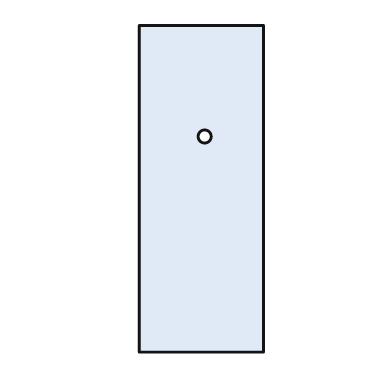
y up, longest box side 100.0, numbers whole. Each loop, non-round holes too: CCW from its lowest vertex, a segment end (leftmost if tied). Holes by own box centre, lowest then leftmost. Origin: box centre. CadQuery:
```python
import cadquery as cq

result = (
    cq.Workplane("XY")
    .moveTo(-19.0, -50.0)
    .lineTo(19.0, -50.0)
    .lineTo(19.0, 50.0)
    .lineTo(-19.0, 50.0)
    .close()
    .moveTo(1.0, 16.0)
    .circle(2.0)
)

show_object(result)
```